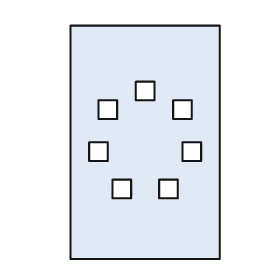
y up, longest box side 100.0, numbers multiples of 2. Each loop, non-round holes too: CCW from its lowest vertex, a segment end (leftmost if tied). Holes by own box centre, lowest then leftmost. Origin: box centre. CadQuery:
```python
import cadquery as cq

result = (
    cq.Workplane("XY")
    .moveTo(-32.0, -50.0)
    .lineTo(32.0, -50.0)
    .lineTo(32.0, 50.0)
    .lineTo(-32.0, 50.0)
    .close()
    .moveTo(-14.0, -24.0)
    .lineTo(-6.0, -24.0)
    .lineTo(-6.0, -16.0)
    .lineTo(-14.0, -16.0)
    .close()
    .moveTo(6.0, -24.0)
    .lineTo(14.0, -24.0)
    .lineTo(14.0, -16.0)
    .lineTo(6.0, -16.0)
    .close()
    .moveTo(-24.0, -8.0)
    .lineTo(-16.0, -8.0)
    .lineTo(-16.0, 0.0)
    .lineTo(-24.0, 0.0)
    .close()
    .moveTo(16.0, -8.0)
    .lineTo(24.0, -8.0)
    .lineTo(24.0, 0.0)
    .lineTo(16.0, 0.0)
    .close()
    .moveTo(-20.0, 10.0)
    .lineTo(-12.0, 10.0)
    .lineTo(-12.0, 18.0)
    .lineTo(-20.0, 18.0)
    .close()
    .moveTo(12.0, 10.0)
    .lineTo(20.0, 10.0)
    .lineTo(20.0, 18.0)
    .lineTo(12.0, 18.0)
    .close()
    .moveTo(-4.0, 18.0)
    .lineTo(4.0, 18.0)
    .lineTo(4.0, 26.0)
    .lineTo(-4.0, 26.0)
    .close()
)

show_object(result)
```